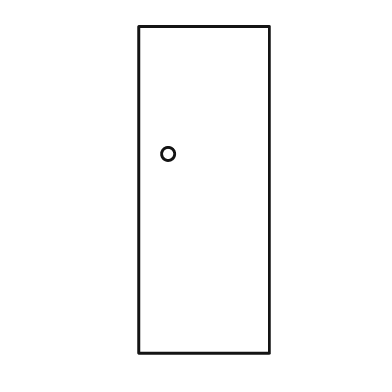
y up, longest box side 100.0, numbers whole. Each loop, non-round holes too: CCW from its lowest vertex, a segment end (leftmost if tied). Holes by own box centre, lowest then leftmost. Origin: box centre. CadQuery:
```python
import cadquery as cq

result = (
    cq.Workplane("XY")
    .moveTo(-20.0, -50.0)
    .lineTo(20.0, -50.0)
    .lineTo(20.0, 50.0)
    .lineTo(-20.0, 50.0)
    .close()
    .moveTo(-11.0, 11.0)
    .circle(2.0)
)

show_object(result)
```